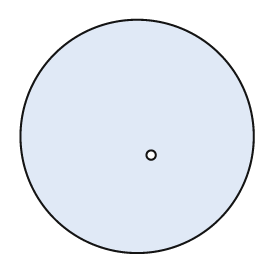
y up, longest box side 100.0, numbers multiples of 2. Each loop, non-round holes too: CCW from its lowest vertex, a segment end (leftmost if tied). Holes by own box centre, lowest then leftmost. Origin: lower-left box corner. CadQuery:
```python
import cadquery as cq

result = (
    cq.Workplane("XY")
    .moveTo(50.0, 50.0)
    .circle(50.0)
    .moveTo(56.0, 42.0)
    .circle(2.0)
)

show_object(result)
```